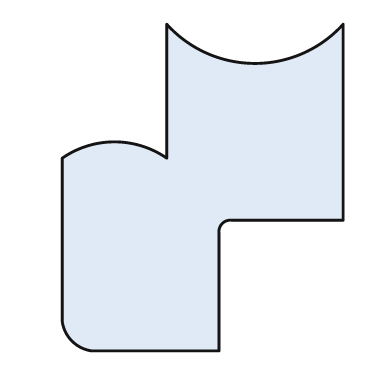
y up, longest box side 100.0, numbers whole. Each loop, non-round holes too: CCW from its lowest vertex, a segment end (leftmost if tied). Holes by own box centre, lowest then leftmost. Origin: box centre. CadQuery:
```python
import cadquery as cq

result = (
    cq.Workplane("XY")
    .moveTo(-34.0, -50.0)
    .lineTo(5.0, -50.0)
    .lineTo(5.0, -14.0)
    .threePointArc((6.0, -11.0), (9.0, -10.0))
    .lineTo(43.0, -10.0)
    .lineTo(43.0, 50.0)
    .threePointArc((16.0, 38.0), (-11.0, 50.0))
    .lineTo(-11.0, 9.0)
    .threePointArc((-27.0, 14.0), (-43.0, 9.0))
    .lineTo(-43.0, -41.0)
    .threePointArc((-40.0, -47.0), (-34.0, -50.0))
    .close()
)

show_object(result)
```